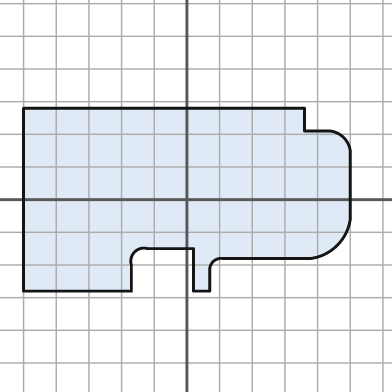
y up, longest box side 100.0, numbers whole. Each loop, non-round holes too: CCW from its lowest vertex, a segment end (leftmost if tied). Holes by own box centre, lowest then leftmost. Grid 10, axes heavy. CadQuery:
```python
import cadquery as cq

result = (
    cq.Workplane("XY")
    .moveTo(-50.0, -28.0)
    .lineTo(-17.0, -28.0)
    .lineTo(-17.0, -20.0)
    .threePointArc((-16.0, -16.0), (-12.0, -15.0))
    .lineTo(2.0, -15.0)
    .lineTo(2.0, -28.0)
    .lineTo(7.0, -28.0)
    .lineTo(7.0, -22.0)
    .threePointArc((8.0, -19.0), (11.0, -18.0))
    .lineTo(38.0, -18.0)
    .threePointArc((46.0, -14.0), (50.0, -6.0))
    .lineTo(50.0, 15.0)
    .threePointArc((48.0, 19.0), (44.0, 21.0))
    .lineTo(36.0, 21.0)
    .lineTo(36.0, 28.0)
    .lineTo(-50.0, 28.0)
    .close()
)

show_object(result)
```